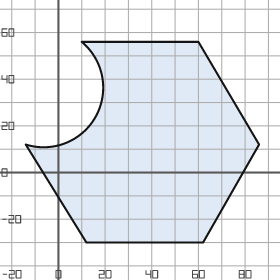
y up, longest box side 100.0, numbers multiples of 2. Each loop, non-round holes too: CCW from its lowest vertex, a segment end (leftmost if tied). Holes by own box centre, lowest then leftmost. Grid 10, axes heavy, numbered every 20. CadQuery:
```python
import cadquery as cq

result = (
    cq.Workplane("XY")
    .moveTo(12.0, -30.0)
    .lineTo(62.0, -30.0)
    .lineTo(86.0, 12.0)
    .lineTo(60.0, 56.0)
    .lineTo(10.0, 56.0)
    .threePointArc((16.0, 24.0), (-14.0, 12.0))
    .close()
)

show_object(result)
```